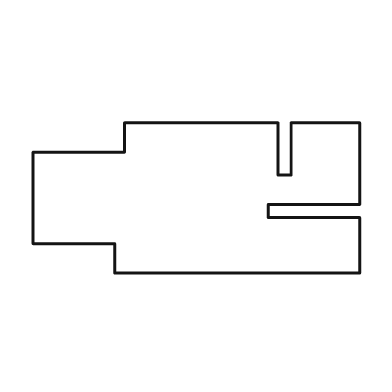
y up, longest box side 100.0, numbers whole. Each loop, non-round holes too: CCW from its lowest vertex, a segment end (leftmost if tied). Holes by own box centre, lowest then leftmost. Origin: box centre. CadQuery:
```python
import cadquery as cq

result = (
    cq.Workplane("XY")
    .moveTo(-25.0, -23.0)
    .lineTo(50.0, -23.0)
    .lineTo(50.0, -6.0)
    .lineTo(22.0, -6.0)
    .lineTo(22.0, -2.0)
    .lineTo(50.0, -2.0)
    .lineTo(50.0, 23.0)
    .lineTo(29.0, 23.0)
    .lineTo(29.0, 7.0)
    .lineTo(25.0, 7.0)
    .lineTo(25.0, 23.0)
    .lineTo(-22.0, 23.0)
    .lineTo(-22.0, 14.0)
    .lineTo(-50.0, 14.0)
    .lineTo(-50.0, -14.0)
    .lineTo(-25.0, -14.0)
    .close()
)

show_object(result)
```